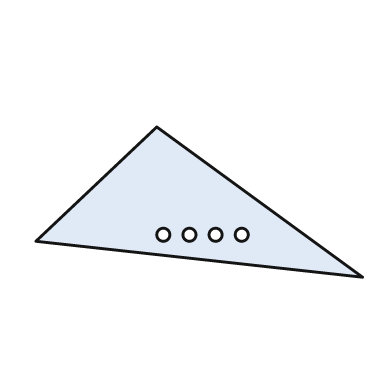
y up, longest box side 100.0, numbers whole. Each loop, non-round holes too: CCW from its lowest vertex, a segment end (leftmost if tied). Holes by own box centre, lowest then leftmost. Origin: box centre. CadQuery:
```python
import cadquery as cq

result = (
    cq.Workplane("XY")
    .moveTo(50.0, -23.0)
    .lineTo(-13.0, 23.0)
    .lineTo(-50.0, -12.0)
    .close()
    .moveTo(-11.0, -10.0)
    .circle(2.0)
    .moveTo(-3.0, -10.0)
    .circle(2.0)
    .moveTo(5.0, -10.0)
    .circle(2.0)
    .moveTo(13.0, -10.0)
    .circle(2.0)
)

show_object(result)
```